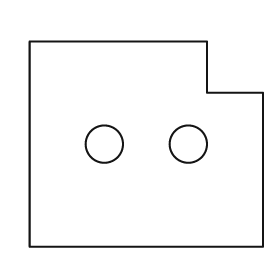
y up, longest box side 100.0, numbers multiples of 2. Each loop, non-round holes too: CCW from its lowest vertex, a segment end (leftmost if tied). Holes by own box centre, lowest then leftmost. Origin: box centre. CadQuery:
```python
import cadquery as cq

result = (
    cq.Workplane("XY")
    .moveTo(-50.0, -44.0)
    .lineTo(50.0, -44.0)
    .lineTo(50.0, 22.0)
    .lineTo(26.0, 22.0)
    .lineTo(26.0, 44.0)
    .lineTo(-50.0, 44.0)
    .close()
    .moveTo(-18.0, 0.0)
    .circle(8.0)
    .moveTo(18.0, 0.0)
    .circle(8.0)
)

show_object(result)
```